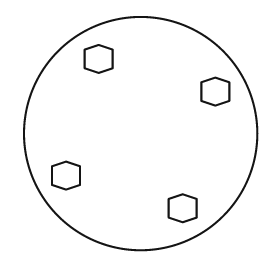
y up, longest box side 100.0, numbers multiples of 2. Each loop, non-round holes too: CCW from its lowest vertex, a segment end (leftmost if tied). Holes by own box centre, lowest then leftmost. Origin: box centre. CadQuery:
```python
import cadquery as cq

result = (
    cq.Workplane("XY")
    .moveTo(0.0, 0.0)
    .circle(50.0)
    .moveTo(18.0, -38.0)
    .lineTo(24.0, -36.0)
    .lineTo(24.0, -28.0)
    .lineTo(18.0, -26.0)
    .lineTo(12.0, -28.0)
    .lineTo(12.0, -36.0)
    .close()
    .moveTo(-32.0, -24.0)
    .lineTo(-26.0, -22.0)
    .lineTo(-26.0, -14.0)
    .lineTo(-32.0, -12.0)
    .lineTo(-38.0, -14.0)
    .lineTo(-38.0, -22.0)
    .close()
    .moveTo(32.0, 12.0)
    .lineTo(38.0, 14.0)
    .lineTo(38.0, 22.0)
    .lineTo(32.0, 24.0)
    .lineTo(26.0, 22.0)
    .lineTo(26.0, 14.0)
    .close()
    .moveTo(-18.0, 26.0)
    .lineTo(-12.0, 28.0)
    .lineTo(-12.0, 36.0)
    .lineTo(-18.0, 38.0)
    .lineTo(-24.0, 36.0)
    .lineTo(-24.0, 28.0)
    .close()
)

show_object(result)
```